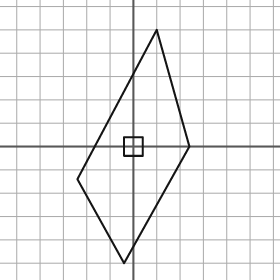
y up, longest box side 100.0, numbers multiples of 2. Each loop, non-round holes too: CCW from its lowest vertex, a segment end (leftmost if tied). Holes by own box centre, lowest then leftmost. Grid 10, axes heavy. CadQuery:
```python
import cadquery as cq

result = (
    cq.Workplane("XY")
    .moveTo(-4.0, -50.0)
    .lineTo(24.0, 0.0)
    .lineTo(10.0, 50.0)
    .lineTo(-24.0, -14.0)
    .close()
    .moveTo(-4.0, -4.0)
    .lineTo(4.0, -4.0)
    .lineTo(4.0, 4.0)
    .lineTo(-4.0, 4.0)
    .close()
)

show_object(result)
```